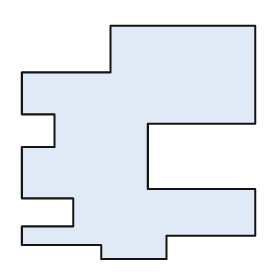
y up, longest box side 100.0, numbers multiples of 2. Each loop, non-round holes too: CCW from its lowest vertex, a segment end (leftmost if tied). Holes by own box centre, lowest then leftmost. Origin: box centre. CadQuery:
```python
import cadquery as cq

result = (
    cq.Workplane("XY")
    .moveTo(-16.0, -50.0)
    .lineTo(12.0, -50.0)
    .lineTo(12.0, -40.0)
    .lineTo(50.0, -40.0)
    .lineTo(50.0, -20.0)
    .lineTo(4.0, -20.0)
    .lineTo(4.0, 8.0)
    .lineTo(50.0, 8.0)
    .lineTo(50.0, 50.0)
    .lineTo(-12.0, 50.0)
    .lineTo(-12.0, 30.0)
    .lineTo(-50.0, 30.0)
    .lineTo(-50.0, 12.0)
    .lineTo(-36.0, 12.0)
    .lineTo(-36.0, -2.0)
    .lineTo(-50.0, -2.0)
    .lineTo(-50.0, -24.0)
    .lineTo(-28.0, -24.0)
    .lineTo(-28.0, -36.0)
    .lineTo(-50.0, -36.0)
    .lineTo(-50.0, -44.0)
    .lineTo(-16.0, -44.0)
    .close()
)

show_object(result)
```